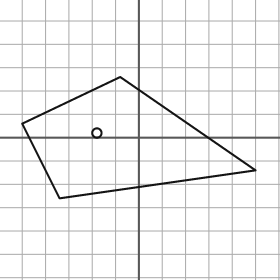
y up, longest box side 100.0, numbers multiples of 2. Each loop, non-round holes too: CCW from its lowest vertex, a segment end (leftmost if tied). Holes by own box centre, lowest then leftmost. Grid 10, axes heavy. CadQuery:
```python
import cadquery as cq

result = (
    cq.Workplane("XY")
    .moveTo(-34.0, -26.0)
    .lineTo(50.0, -14.0)
    .lineTo(-8.0, 26.0)
    .lineTo(-50.0, 6.0)
    .close()
    .moveTo(-18.0, 2.0)
    .circle(2.0)
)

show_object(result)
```